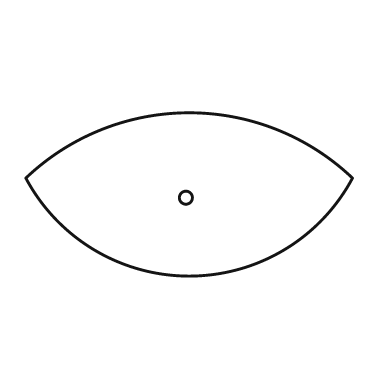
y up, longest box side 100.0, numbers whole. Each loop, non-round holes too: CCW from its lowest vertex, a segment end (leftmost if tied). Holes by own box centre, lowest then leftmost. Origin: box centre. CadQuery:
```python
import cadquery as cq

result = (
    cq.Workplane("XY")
    .moveTo(-50.0, 5.0)
    .threePointArc((0.0, -25.0), (50.0, 5.0))
    .threePointArc((0.0, 25.0), (-50.0, 5.0))
    .close()
    .moveTo(-1.0, -1.0)
    .circle(2.0)
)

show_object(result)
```